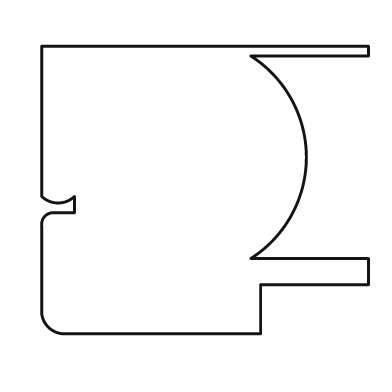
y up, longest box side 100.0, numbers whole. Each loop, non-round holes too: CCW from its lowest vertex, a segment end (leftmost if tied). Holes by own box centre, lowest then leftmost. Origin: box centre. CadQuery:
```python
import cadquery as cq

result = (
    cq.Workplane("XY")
    .moveTo(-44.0, -44.0)
    .lineTo(17.0, -44.0)
    .lineTo(17.0, -29.0)
    .lineTo(50.0, -29.0)
    .lineTo(50.0, -21.0)
    .lineTo(14.0, -21.0)
    .threePointArc((31.0, 10.0), (14.0, 41.0))
    .lineTo(50.0, 41.0)
    .lineTo(50.0, 44.0)
    .lineTo(-50.0, 44.0)
    .lineTo(-50.0, -2.0)
    .threePointArc((-45.0, -4.0), (-40.0, -2.0))
    .lineTo(-40.0, -7.0)
    .lineTo(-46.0, -7.0)
    .threePointArc((-49.0, -8.0), (-50.0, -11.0))
    .lineTo(-50.0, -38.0)
    .threePointArc((-48.0, -42.0), (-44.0, -44.0))
    .close()
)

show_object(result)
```